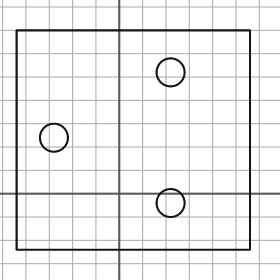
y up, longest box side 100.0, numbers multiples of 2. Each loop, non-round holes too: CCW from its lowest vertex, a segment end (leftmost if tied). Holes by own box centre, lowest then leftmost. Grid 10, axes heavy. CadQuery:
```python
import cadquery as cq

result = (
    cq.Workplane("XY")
    .moveTo(-44.0, -24.0)
    .lineTo(56.0, -24.0)
    .lineTo(56.0, 70.0)
    .lineTo(-44.0, 70.0)
    .close()
    .moveTo(22.0, -4.0)
    .circle(6.0)
    .moveTo(-28.0, 24.0)
    .circle(6.0)
    .moveTo(22.0, 52.0)
    .circle(6.0)
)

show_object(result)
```